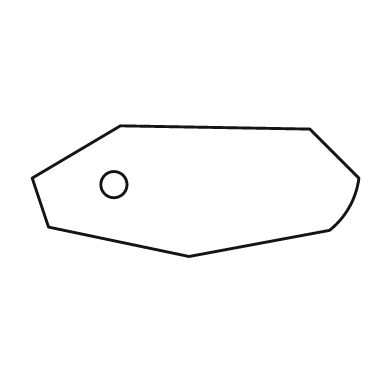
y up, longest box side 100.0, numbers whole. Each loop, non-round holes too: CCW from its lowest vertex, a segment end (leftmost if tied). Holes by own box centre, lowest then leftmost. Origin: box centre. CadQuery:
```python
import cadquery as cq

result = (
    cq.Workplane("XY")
    .moveTo(-2.0, -20.0)
    .lineTo(41.0, -12.0)
    .threePointArc((47.0, -5.0), (50.0, 4.0))
    .lineTo(35.0, 19.0)
    .lineTo(-23.0, 20.0)
    .lineTo(-50.0, 4.0)
    .lineTo(-45.0, -11.0)
    .close()
    .moveTo(-25.0, 2.0)
    .circle(4.0)
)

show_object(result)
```